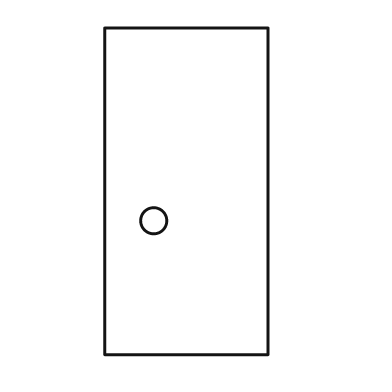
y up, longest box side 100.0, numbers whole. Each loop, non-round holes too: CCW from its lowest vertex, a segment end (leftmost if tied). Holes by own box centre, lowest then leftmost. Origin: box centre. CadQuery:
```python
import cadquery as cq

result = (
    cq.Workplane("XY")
    .moveTo(-25.0, -50.0)
    .lineTo(25.0, -50.0)
    .lineTo(25.0, 50.0)
    .lineTo(-25.0, 50.0)
    .close()
    .moveTo(-10.0, -9.0)
    .circle(4.0)
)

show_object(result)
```